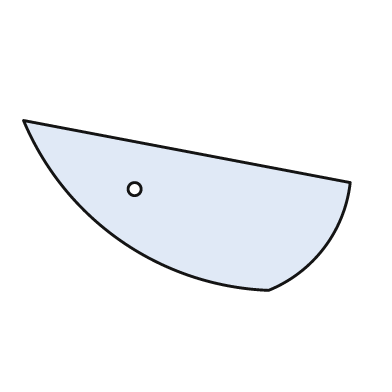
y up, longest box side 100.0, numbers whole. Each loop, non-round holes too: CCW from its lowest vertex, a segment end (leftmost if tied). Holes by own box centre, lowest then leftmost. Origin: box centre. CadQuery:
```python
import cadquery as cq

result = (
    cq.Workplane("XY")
    .moveTo(25.0, -26.0)
    .threePointArc((42.0, -13.0), (50.0, 7.0))
    .lineTo(-50.0, 26.0)
    .threePointArc((-20.0, -11.0), (25.0, -26.0))
    .close()
    .moveTo(-16.0, 5.0)
    .circle(2.0)
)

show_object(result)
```